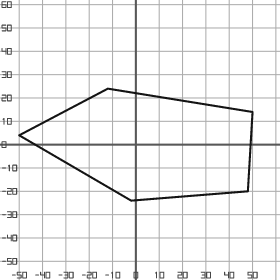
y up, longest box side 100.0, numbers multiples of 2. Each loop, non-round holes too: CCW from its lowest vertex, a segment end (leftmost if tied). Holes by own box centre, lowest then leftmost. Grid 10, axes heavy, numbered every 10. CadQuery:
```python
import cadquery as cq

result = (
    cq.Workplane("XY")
    .moveTo(-2.0, -24.0)
    .lineTo(48.0, -20.0)
    .lineTo(50.0, 14.0)
    .lineTo(-12.0, 24.0)
    .lineTo(-50.0, 4.0)
    .close()
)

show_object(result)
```